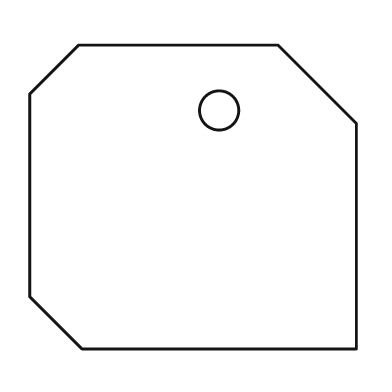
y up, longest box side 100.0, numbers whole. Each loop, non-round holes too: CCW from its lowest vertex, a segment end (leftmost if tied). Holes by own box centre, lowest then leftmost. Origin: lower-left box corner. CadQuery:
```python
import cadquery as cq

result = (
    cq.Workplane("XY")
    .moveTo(16.0, 0.0)
    .lineTo(100.0, 0.0)
    .lineTo(100.0, 69.0)
    .lineTo(76.0, 93.0)
    .lineTo(15.0, 93.0)
    .lineTo(0.0, 78.0)
    .lineTo(0.0, 16.0)
    .close()
    .moveTo(58.0, 73.0)
    .circle(6.0)
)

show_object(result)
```